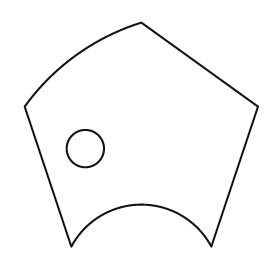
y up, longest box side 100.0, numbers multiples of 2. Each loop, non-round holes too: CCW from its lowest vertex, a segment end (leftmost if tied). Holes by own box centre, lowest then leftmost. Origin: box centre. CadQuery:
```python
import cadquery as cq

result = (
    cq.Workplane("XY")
    .moveTo(-30.0, -48.0)
    .threePointArc((0.0, -30.0), (30.0, -48.0))
    .lineTo(50.0, 12.0)
    .lineTo(0.0, 48.0)
    .threePointArc((-28.0, 34.0), (-50.0, 12.0))
    .close()
    .moveTo(-24.0, -6.0)
    .circle(8.0)
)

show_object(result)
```